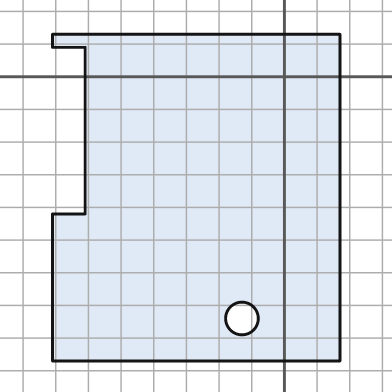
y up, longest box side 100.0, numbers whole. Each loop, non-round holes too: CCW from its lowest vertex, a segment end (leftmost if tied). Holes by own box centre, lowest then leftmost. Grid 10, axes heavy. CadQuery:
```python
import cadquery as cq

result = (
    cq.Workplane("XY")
    .moveTo(-71.0, -87.0)
    .lineTo(17.0, -87.0)
    .lineTo(17.0, 13.0)
    .lineTo(-71.0, 13.0)
    .lineTo(-71.0, 9.0)
    .lineTo(-61.0, 9.0)
    .lineTo(-61.0, -42.0)
    .lineTo(-71.0, -42.0)
    .close()
    .moveTo(-13.0, -74.0)
    .circle(5.0)
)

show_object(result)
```